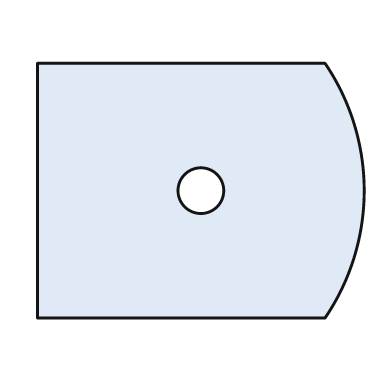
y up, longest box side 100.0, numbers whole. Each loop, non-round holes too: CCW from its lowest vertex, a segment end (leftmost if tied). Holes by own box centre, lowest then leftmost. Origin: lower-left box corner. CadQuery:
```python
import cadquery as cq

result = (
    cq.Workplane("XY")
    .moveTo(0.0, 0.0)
    .lineTo(88.0, 0.0)
    .threePointArc((100.0, 39.0), (88.0, 78.0))
    .lineTo(0.0, 78.0)
    .close()
    .moveTo(50.0, 39.0)
    .circle(7.0)
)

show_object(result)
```